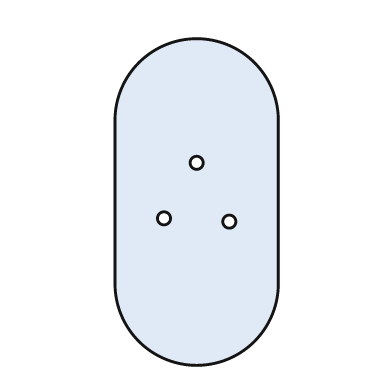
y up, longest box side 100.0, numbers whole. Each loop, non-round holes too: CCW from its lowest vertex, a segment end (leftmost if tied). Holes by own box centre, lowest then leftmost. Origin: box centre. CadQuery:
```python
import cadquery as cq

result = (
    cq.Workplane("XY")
    .moveTo(-25.0, -25.0)
    .threePointArc((0.0, -50.0), (25.0, -25.0))
    .lineTo(25.0, 25.0)
    .threePointArc((0.0, 50.0), (-25.0, 25.0))
    .close()
    .moveTo(10.0, -6.0)
    .circle(2.0)
    .moveTo(-10.0, -5.0)
    .circle(2.0)
    .moveTo(0.0, 12.0)
    .circle(2.0)
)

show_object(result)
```